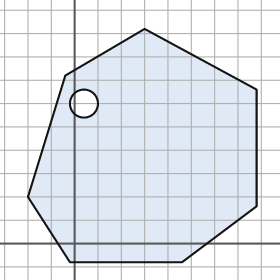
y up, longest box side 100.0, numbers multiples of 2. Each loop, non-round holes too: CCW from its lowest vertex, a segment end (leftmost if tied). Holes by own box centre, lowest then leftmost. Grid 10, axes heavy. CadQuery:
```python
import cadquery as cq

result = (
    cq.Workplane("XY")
    .moveTo(-2.0, -8.0)
    .lineTo(46.0, -8.0)
    .lineTo(78.0, 16.0)
    .lineTo(78.0, 66.0)
    .lineTo(30.0, 92.0)
    .lineTo(-4.0, 72.0)
    .lineTo(-20.0, 20.0)
    .close()
    .moveTo(4.0, 60.0)
    .circle(6.0)
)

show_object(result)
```